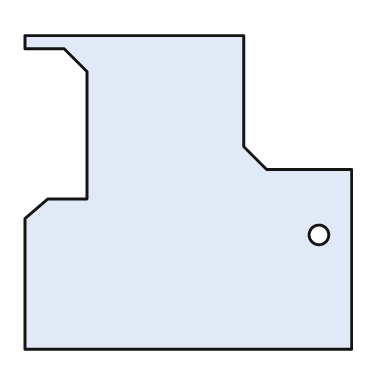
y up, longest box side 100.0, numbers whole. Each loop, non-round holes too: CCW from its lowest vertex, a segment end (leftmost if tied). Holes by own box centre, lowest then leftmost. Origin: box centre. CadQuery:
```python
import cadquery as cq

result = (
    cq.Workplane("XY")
    .moveTo(-50.0, -48.0)
    .lineTo(50.0, -48.0)
    .lineTo(50.0, 7.0)
    .lineTo(24.0, 7.0)
    .lineTo(17.0, 14.0)
    .lineTo(17.0, 48.0)
    .lineTo(-50.0, 48.0)
    .lineTo(-50.0, 44.0)
    .lineTo(-38.0, 44.0)
    .lineTo(-31.0, 37.0)
    .lineTo(-31.0, -2.0)
    .lineTo(-43.0, -2.0)
    .lineTo(-50.0, -8.0)
    .close()
    .moveTo(40.0, -13.0)
    .circle(3.0)
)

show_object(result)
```